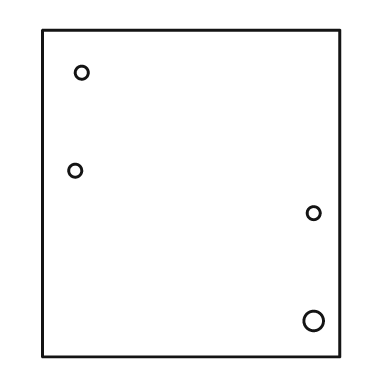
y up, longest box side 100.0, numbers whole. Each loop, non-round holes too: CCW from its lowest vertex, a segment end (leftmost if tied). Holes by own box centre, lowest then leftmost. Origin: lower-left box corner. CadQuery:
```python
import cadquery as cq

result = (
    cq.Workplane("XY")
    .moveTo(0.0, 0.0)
    .lineTo(91.0, 0.0)
    .lineTo(91.0, 100.0)
    .lineTo(0.0, 100.0)
    .close()
    .moveTo(83.0, 11.0)
    .circle(3.0)
    .moveTo(83.0, 44.0)
    .circle(2.0)
    .moveTo(10.0, 57.0)
    .circle(2.0)
    .moveTo(12.0, 87.0)
    .circle(2.0)
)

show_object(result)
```